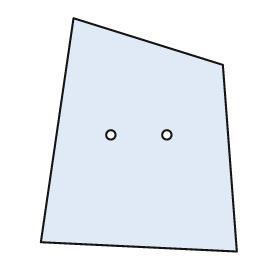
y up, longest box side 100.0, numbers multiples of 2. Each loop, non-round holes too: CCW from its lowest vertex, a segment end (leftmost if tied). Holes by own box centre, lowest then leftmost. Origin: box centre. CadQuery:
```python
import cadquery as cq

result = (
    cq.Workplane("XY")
    .moveTo(42.0, -50.0)
    .lineTo(36.0, 30.0)
    .lineTo(-28.0, 50.0)
    .lineTo(-42.0, -46.0)
    .close()
    .moveTo(-12.0, 0.0)
    .circle(2.0)
    .moveTo(12.0, 0.0)
    .circle(2.0)
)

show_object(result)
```